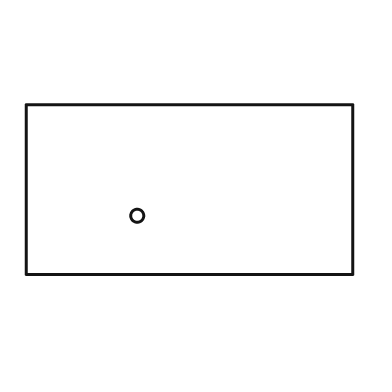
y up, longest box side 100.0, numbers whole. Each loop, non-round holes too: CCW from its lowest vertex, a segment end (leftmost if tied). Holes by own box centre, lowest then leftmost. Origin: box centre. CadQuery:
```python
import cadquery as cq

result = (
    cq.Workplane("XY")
    .moveTo(-50.0, -26.0)
    .lineTo(50.0, -26.0)
    .lineTo(50.0, 26.0)
    .lineTo(-50.0, 26.0)
    .close()
    .moveTo(-16.0, -8.0)
    .circle(2.0)
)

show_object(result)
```